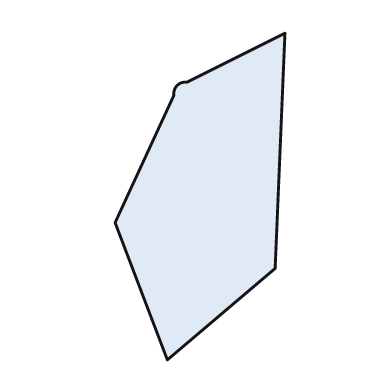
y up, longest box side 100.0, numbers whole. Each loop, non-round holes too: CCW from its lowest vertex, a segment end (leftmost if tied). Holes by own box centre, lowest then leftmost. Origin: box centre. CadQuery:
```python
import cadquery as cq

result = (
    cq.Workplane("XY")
    .moveTo(-10.0, -50.0)
    .lineTo(23.0, -22.0)
    .lineTo(26.0, 50.0)
    .lineTo(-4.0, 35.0)
    .threePointArc((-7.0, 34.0), (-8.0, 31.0))
    .lineTo(-26.0, -8.0)
    .close()
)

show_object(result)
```